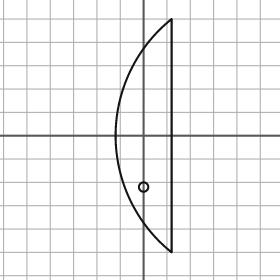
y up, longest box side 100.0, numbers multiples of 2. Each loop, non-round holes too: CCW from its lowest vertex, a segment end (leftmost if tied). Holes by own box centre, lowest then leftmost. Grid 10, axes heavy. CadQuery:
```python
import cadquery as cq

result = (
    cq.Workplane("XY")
    .moveTo(12.0, -50.0)
    .lineTo(12.0, 50.0)
    .threePointArc((-12.0, 0.0), (12.0, -50.0))
    .close()
    .moveTo(0.0, -22.0)
    .circle(2.0)
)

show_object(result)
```